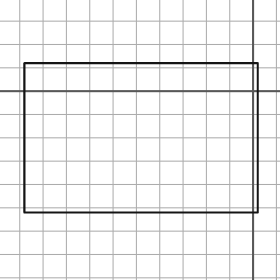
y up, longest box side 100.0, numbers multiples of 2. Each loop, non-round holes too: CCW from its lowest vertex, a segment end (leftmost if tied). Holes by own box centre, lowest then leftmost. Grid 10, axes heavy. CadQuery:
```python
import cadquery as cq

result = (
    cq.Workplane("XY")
    .moveTo(-98.0, -52.0)
    .lineTo(2.0, -52.0)
    .lineTo(2.0, 12.0)
    .lineTo(-98.0, 12.0)
    .close()
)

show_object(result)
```